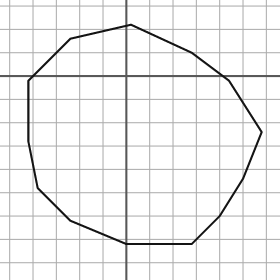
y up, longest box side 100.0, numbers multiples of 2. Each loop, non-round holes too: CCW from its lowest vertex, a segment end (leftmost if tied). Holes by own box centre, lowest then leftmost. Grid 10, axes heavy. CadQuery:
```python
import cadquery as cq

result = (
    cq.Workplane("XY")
    .moveTo(0.0, -72.0)
    .lineTo(28.0, -72.0)
    .lineTo(40.0, -60.0)
    .lineTo(50.0, -44.0)
    .lineTo(58.0, -24.0)
    .lineTo(44.0, -2.0)
    .lineTo(28.0, 10.0)
    .lineTo(2.0, 22.0)
    .lineTo(-24.0, 16.0)
    .lineTo(-42.0, -2.0)
    .lineTo(-42.0, -28.0)
    .lineTo(-38.0, -48.0)
    .lineTo(-24.0, -62.0)
    .close()
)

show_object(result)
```